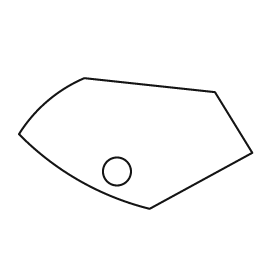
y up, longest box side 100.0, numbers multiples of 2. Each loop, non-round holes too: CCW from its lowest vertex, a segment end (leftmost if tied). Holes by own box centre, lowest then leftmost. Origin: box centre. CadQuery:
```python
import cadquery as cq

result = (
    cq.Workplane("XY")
    .moveTo(6.0, -28.0)
    .lineTo(50.0, -4.0)
    .lineTo(34.0, 22.0)
    .lineTo(-22.0, 28.0)
    .threePointArc((-38.0, 18.0), (-50.0, 4.0))
    .threePointArc((-24.0, -16.0), (6.0, -28.0))
    .close()
    .moveTo(-8.0, -12.0)
    .circle(6.0)
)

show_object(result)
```